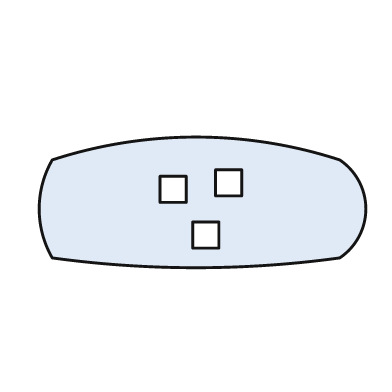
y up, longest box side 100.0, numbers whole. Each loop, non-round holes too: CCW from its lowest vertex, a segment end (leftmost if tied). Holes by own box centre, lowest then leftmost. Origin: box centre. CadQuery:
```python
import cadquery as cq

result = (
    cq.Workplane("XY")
    .moveTo(-46.0, -17.0)
    .threePointArc((-2.0, -20.0), (42.0, -17.0))
    .threePointArc((50.0, -2.0), (42.0, 13.0))
    .threePointArc((-2.0, 20.0), (-46.0, 13.0))
    .threePointArc((-50.0, -2.0), (-46.0, -17.0))
    .close()
    .moveTo(-3.0, -14.0)
    .lineTo(5.0, -14.0)
    .lineTo(5.0, -6.0)
    .lineTo(-3.0, -6.0)
    .close()
    .moveTo(-13.0, 0.0)
    .lineTo(-5.0, 0.0)
    .lineTo(-5.0, 8.0)
    .lineTo(-13.0, 8.0)
    .close()
    .moveTo(4.0, 2.0)
    .lineTo(12.0, 2.0)
    .lineTo(12.0, 10.0)
    .lineTo(4.0, 10.0)
    .close()
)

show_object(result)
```